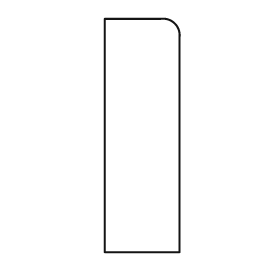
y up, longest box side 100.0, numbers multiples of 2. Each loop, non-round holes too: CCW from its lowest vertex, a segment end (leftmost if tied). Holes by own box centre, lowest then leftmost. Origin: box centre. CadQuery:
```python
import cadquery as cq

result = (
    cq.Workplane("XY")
    .moveTo(-16.0, -50.0)
    .lineTo(16.0, -50.0)
    .lineTo(16.0, 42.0)
    .threePointArc((14.0, 48.0), (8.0, 50.0))
    .lineTo(-16.0, 50.0)
    .close()
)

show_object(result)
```